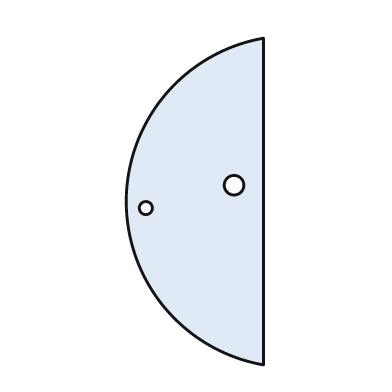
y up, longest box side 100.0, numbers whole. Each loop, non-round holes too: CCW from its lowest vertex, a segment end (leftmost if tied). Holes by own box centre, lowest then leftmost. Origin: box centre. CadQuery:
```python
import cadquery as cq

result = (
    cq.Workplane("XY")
    .moveTo(21.0, -50.0)
    .lineTo(21.0, 50.0)
    .threePointArc((-21.0, 0.0), (21.0, -50.0))
    .close()
    .moveTo(-15.0, -2.0)
    .circle(2.0)
    .moveTo(12.0, 5.0)
    .circle(3.0)
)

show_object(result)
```